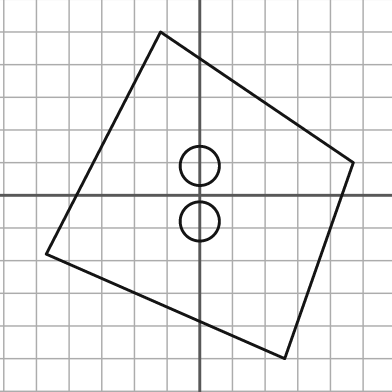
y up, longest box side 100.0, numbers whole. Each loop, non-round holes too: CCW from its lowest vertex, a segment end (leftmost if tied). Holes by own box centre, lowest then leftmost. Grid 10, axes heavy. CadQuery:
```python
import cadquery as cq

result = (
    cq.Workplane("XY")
    .moveTo(26.0, -50.0)
    .lineTo(47.0, 10.0)
    .lineTo(-12.0, 50.0)
    .lineTo(-47.0, -18.0)
    .close()
    .moveTo(0.0, -8.0)
    .circle(6.0)
    .moveTo(0.0, 9.0)
    .circle(6.0)
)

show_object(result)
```